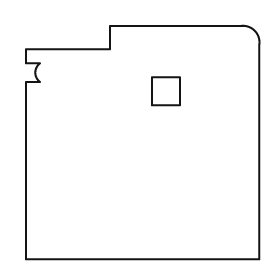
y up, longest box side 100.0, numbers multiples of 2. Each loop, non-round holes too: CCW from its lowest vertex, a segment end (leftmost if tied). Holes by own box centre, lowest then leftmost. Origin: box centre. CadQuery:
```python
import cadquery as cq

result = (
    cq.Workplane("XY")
    .moveTo(-50.0, -50.0)
    .lineTo(50.0, -50.0)
    .lineTo(50.0, 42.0)
    .threePointArc((48.0, 48.0), (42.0, 50.0))
    .lineTo(-14.0, 50.0)
    .lineTo(-14.0, 40.0)
    .lineTo(-50.0, 40.0)
    .lineTo(-50.0, 34.0)
    .lineTo(-44.0, 34.0)
    .threePointArc((-46.0, 30.0), (-44.0, 26.0))
    .lineTo(-50.0, 26.0)
    .close()
    .moveTo(4.0, 16.0)
    .lineTo(16.0, 16.0)
    .lineTo(16.0, 28.0)
    .lineTo(4.0, 28.0)
    .close()
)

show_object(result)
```